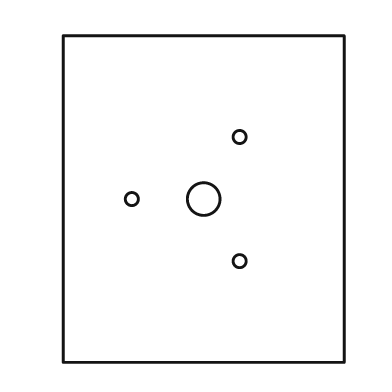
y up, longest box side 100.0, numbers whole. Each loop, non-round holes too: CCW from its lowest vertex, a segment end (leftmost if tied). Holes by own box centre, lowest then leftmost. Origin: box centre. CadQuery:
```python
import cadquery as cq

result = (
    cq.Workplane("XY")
    .moveTo(-43.0, -50.0)
    .lineTo(43.0, -50.0)
    .lineTo(43.0, 50.0)
    .lineTo(-43.0, 50.0)
    .close()
    .moveTo(11.0, -19.0)
    .circle(2.0)
    .moveTo(-22.0, 0.0)
    .circle(2.0)
    .moveTo(0.0, 0.0)
    .circle(5.0)
    .moveTo(11.0, 19.0)
    .circle(2.0)
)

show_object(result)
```